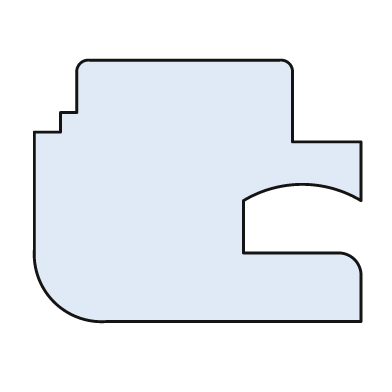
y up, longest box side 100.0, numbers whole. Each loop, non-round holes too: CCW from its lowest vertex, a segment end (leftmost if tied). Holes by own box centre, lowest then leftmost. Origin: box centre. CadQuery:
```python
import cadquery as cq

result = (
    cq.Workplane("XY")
    .moveTo(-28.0, -40.0)
    .lineTo(50.0, -40.0)
    .lineTo(50.0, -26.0)
    .threePointArc((48.0, -21.0), (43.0, -19.0))
    .lineTo(14.0, -19.0)
    .lineTo(14.0, -3.0)
    .threePointArc((32.0, 2.0), (50.0, -3.0))
    .lineTo(50.0, 15.0)
    .lineTo(29.0, 15.0)
    .lineTo(29.0, 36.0)
    .threePointArc((28.0, 39.0), (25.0, 40.0))
    .lineTo(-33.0, 40.0)
    .threePointArc((-36.0, 39.0), (-37.0, 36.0))
    .lineTo(-37.0, 24.0)
    .lineTo(-42.0, 24.0)
    .lineTo(-42.0, 18.0)
    .lineTo(-50.0, 18.0)
    .lineTo(-50.0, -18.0)
    .threePointArc((-44.0, -34.0), (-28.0, -40.0))
    .close()
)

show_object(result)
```